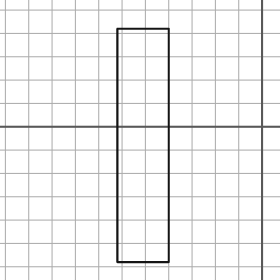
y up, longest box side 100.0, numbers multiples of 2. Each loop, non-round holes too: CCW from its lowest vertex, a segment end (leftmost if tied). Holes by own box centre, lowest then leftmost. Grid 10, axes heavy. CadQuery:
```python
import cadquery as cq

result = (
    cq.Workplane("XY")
    .moveTo(-62.0, -58.0)
    .lineTo(-40.0, -58.0)
    .lineTo(-40.0, 42.0)
    .lineTo(-62.0, 42.0)
    .close()
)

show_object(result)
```